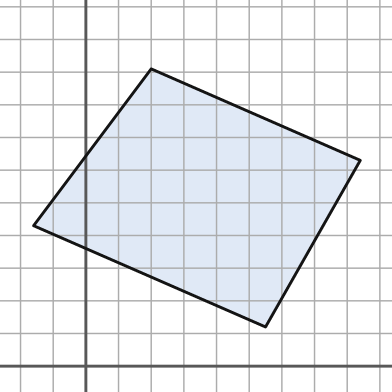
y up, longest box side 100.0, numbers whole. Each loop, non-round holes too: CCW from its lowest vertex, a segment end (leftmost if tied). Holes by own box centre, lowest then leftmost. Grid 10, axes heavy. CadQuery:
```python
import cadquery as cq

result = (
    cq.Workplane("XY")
    .moveTo(55.0, 12.0)
    .lineTo(84.0, 63.0)
    .lineTo(20.0, 91.0)
    .lineTo(-16.0, 43.0)
    .close()
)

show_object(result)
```